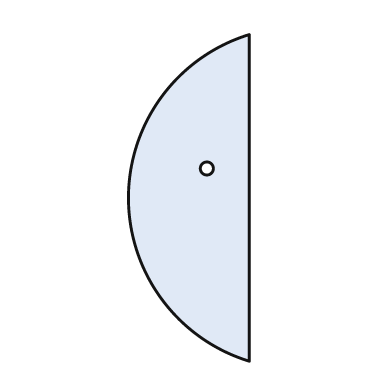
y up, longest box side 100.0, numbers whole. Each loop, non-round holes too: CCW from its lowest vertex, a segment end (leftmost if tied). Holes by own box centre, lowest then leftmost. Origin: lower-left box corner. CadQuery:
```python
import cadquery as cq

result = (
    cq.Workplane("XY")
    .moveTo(37.0, 0.0)
    .lineTo(37.0, 100.0)
    .threePointArc((0.0, 50.0), (37.0, 0.0))
    .close()
    .moveTo(24.0, 59.0)
    .circle(2.0)
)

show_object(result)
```